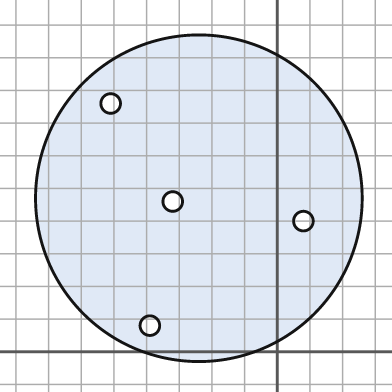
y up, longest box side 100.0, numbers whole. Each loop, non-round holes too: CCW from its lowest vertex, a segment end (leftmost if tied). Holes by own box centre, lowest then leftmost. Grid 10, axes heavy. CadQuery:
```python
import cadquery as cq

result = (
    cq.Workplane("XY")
    .moveTo(-24.0, 47.0)
    .circle(50.0)
    .moveTo(-39.0, 8.0)
    .circle(3.0)
    .moveTo(8.0, 40.0)
    .circle(3.0)
    .moveTo(-32.0, 46.0)
    .circle(3.0)
    .moveTo(-51.0, 76.0)
    .circle(3.0)
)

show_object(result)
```